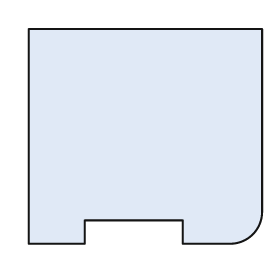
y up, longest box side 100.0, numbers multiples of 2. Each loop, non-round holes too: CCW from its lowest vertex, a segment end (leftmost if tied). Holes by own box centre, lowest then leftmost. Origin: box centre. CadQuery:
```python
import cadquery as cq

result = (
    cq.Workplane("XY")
    .moveTo(-50.0, -46.0)
    .lineTo(-26.0, -46.0)
    .lineTo(-26.0, -36.0)
    .lineTo(16.0, -36.0)
    .lineTo(16.0, -46.0)
    .lineTo(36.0, -46.0)
    .threePointArc((46.0, -42.0), (50.0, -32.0))
    .lineTo(50.0, 46.0)
    .lineTo(-50.0, 46.0)
    .close()
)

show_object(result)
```